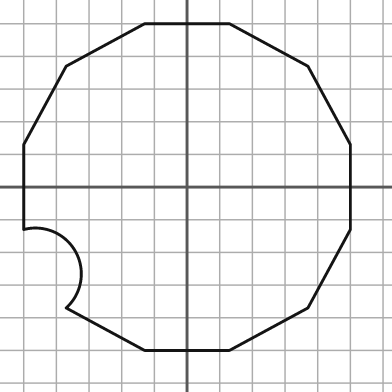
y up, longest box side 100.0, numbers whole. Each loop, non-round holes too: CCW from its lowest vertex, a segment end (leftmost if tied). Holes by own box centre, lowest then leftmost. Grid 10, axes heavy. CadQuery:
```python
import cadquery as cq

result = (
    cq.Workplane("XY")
    .moveTo(-13.0, -50.0)
    .lineTo(13.0, -50.0)
    .lineTo(37.0, -37.0)
    .lineTo(50.0, -13.0)
    .lineTo(50.0, 13.0)
    .lineTo(37.0, 37.0)
    .lineTo(13.0, 50.0)
    .lineTo(-13.0, 50.0)
    .lineTo(-37.0, 37.0)
    .lineTo(-50.0, 13.0)
    .lineTo(-50.0, -13.0)
    .threePointArc((-34.0, -20.0), (-37.0, -37.0))
    .close()
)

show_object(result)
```